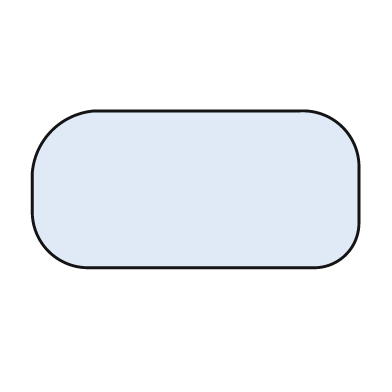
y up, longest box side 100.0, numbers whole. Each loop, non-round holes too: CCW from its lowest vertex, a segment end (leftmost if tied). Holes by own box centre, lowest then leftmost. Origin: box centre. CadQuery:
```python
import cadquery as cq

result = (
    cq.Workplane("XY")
    .moveTo(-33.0, -24.0)
    .lineTo(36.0, -24.0)
    .threePointArc((46.0, -20.0), (50.0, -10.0))
    .lineTo(50.0, 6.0)
    .threePointArc((45.0, 19.0), (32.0, 24.0))
    .lineTo(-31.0, 24.0)
    .threePointArc((-44.0, 18.0), (-50.0, 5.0))
    .lineTo(-50.0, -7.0)
    .threePointArc((-45.0, -19.0), (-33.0, -24.0))
    .close()
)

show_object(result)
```